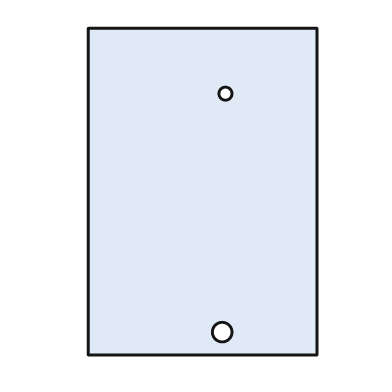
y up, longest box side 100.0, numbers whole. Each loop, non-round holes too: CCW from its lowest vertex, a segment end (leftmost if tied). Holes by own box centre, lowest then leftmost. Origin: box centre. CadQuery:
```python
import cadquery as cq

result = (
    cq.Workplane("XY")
    .moveTo(-35.0, -50.0)
    .lineTo(35.0, -50.0)
    .lineTo(35.0, 50.0)
    .lineTo(-35.0, 50.0)
    .close()
    .moveTo(6.0, -43.0)
    .circle(3.0)
    .moveTo(7.0, 30.0)
    .circle(2.0)
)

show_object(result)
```